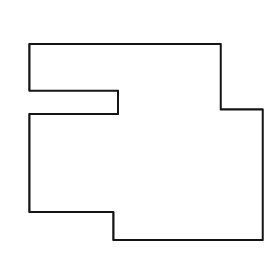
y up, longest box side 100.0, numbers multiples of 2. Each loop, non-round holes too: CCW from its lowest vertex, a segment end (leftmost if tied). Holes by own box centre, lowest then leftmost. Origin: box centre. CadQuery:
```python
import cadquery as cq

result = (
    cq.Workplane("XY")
    .moveTo(-14.0, -42.0)
    .lineTo(50.0, -42.0)
    .lineTo(50.0, 14.0)
    .lineTo(32.0, 14.0)
    .lineTo(32.0, 42.0)
    .lineTo(-50.0, 42.0)
    .lineTo(-50.0, 22.0)
    .lineTo(-12.0, 22.0)
    .lineTo(-12.0, 12.0)
    .lineTo(-50.0, 12.0)
    .lineTo(-50.0, -30.0)
    .lineTo(-14.0, -30.0)
    .close()
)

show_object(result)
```